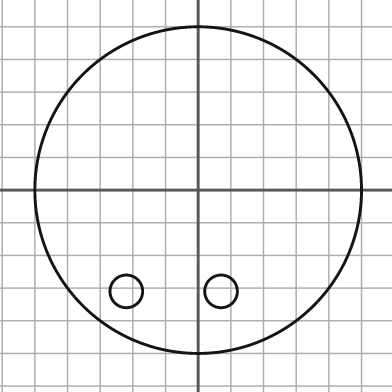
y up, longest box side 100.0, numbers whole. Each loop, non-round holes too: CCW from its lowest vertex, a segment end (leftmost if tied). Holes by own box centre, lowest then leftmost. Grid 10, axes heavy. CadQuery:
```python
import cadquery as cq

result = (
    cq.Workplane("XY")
    .moveTo(0.0, 0.0)
    .circle(50.0)
    .moveTo(-22.0, -31.0)
    .circle(5.0)
    .moveTo(7.0, -31.0)
    .circle(5.0)
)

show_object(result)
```